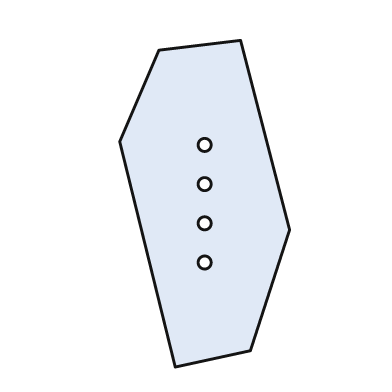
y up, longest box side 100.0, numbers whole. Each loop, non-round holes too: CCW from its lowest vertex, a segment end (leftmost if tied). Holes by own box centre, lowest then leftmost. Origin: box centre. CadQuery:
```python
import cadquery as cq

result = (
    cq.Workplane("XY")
    .moveTo(-9.0, -50.0)
    .lineTo(14.0, -45.0)
    .lineTo(26.0, -8.0)
    .lineTo(11.0, 50.0)
    .lineTo(-14.0, 47.0)
    .lineTo(-26.0, 19.0)
    .close()
    .moveTo(0.0, -18.0)
    .circle(2.0)
    .moveTo(0.0, -6.0)
    .circle(2.0)
    .moveTo(0.0, 6.0)
    .circle(2.0)
    .moveTo(0.0, 18.0)
    .circle(2.0)
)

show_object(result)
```